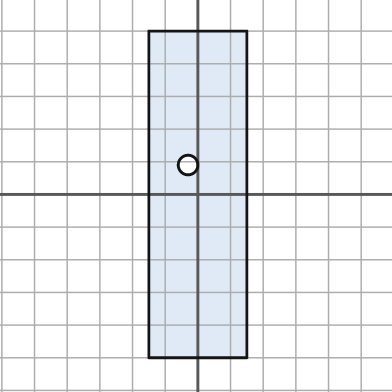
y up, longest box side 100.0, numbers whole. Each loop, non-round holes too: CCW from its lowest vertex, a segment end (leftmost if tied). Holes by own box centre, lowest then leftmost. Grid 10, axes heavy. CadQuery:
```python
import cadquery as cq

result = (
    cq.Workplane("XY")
    .moveTo(-15.0, -50.0)
    .lineTo(15.0, -50.0)
    .lineTo(15.0, 50.0)
    .lineTo(-15.0, 50.0)
    .close()
    .moveTo(-3.0, 9.0)
    .circle(3.0)
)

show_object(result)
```